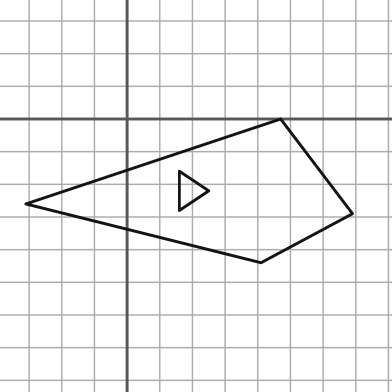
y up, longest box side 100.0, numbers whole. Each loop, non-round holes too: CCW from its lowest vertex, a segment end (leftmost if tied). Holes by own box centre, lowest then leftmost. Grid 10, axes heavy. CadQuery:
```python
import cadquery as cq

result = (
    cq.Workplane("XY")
    .moveTo(41.0, -44.0)
    .lineTo(69.0, -29.0)
    .lineTo(47.0, 0.0)
    .lineTo(-31.0, -26.0)
    .close()
    .moveTo(16.0, -28.0)
    .lineTo(25.0, -22.0)
    .lineTo(16.0, -16.0)
    .close()
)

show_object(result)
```